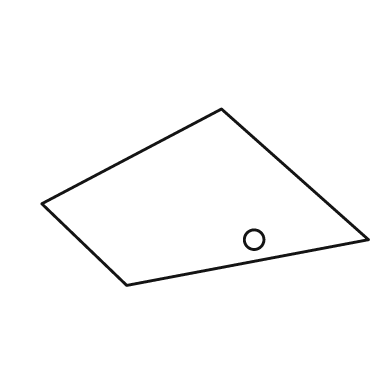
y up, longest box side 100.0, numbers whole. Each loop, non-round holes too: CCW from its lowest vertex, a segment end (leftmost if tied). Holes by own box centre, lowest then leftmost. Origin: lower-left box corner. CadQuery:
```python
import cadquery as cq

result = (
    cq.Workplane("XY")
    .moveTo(26.0, 0.0)
    .lineTo(100.0, 14.0)
    .lineTo(55.0, 54.0)
    .lineTo(0.0, 25.0)
    .close()
    .moveTo(65.0, 14.0)
    .circle(3.0)
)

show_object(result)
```